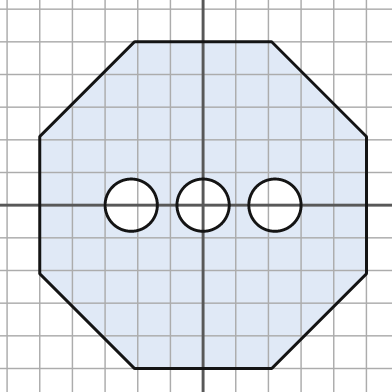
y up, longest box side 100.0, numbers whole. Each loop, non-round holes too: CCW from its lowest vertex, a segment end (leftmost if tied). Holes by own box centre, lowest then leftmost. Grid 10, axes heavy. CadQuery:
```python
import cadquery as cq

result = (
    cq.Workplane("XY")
    .moveTo(-21.0, -50.0)
    .lineTo(21.0, -50.0)
    .lineTo(50.0, -21.0)
    .lineTo(50.0, 21.0)
    .lineTo(21.0, 50.0)
    .lineTo(-21.0, 50.0)
    .lineTo(-50.0, 21.0)
    .lineTo(-50.0, -21.0)
    .close()
    .moveTo(-22.0, 0.0)
    .circle(8.0)
    .moveTo(0.0, 0.0)
    .circle(8.0)
    .moveTo(22.0, 0.0)
    .circle(8.0)
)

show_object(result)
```